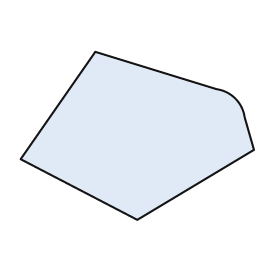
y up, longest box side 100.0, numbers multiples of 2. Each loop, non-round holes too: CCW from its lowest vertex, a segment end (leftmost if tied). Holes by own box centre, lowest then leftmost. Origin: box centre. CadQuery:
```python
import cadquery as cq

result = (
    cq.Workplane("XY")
    .moveTo(0.0, -36.0)
    .lineTo(50.0, -6.0)
    .lineTo(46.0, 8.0)
    .threePointArc((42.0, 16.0), (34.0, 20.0))
    .lineTo(-18.0, 36.0)
    .lineTo(-50.0, -10.0)
    .close()
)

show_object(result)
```